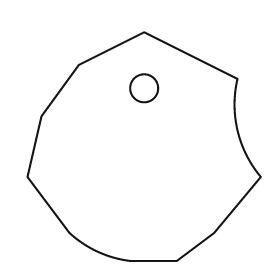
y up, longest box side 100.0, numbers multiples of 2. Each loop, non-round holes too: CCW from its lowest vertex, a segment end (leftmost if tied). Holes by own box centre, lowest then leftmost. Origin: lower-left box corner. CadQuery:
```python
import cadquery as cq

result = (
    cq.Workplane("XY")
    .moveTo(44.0, 0.0)
    .lineTo(64.0, 0.0)
    .lineTo(80.0, 12.0)
    .lineTo(100.0, 36.0)
    .threePointArc((90.0, 56.0), (90.0, 78.0))
    .lineTo(50.0, 98.0)
    .lineTo(22.0, 84.0)
    .lineTo(6.0, 62.0)
    .lineTo(0.0, 36.0)
    .lineTo(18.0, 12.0)
    .threePointArc((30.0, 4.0), (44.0, 0.0))
    .close()
    .moveTo(50.0, 74.0)
    .circle(6.0)
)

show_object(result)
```